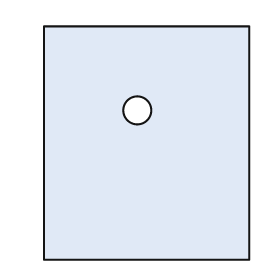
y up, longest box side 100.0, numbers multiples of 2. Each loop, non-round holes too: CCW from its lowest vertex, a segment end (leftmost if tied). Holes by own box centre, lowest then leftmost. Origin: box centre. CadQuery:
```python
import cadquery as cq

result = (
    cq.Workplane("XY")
    .moveTo(-44.0, -50.0)
    .lineTo(44.0, -50.0)
    .lineTo(44.0, 50.0)
    .lineTo(-44.0, 50.0)
    .close()
    .moveTo(-4.0, 14.0)
    .circle(6.0)
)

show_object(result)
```